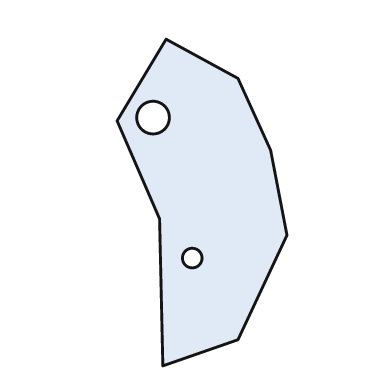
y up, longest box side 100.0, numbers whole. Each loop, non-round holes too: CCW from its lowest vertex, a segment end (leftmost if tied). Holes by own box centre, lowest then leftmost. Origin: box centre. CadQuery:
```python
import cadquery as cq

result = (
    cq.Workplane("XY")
    .moveTo(-12.0, -50.0)
    .lineTo(11.0, -42.0)
    .lineTo(26.0, -10.0)
    .lineTo(21.0, 16.0)
    .lineTo(11.0, 38.0)
    .lineTo(-11.0, 50.0)
    .lineTo(-26.0, 25.0)
    .lineTo(-13.0, -5.0)
    .close()
    .moveTo(-3.0, -17.0)
    .circle(3.0)
    .moveTo(-15.0, 26.0)
    .circle(5.0)
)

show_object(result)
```